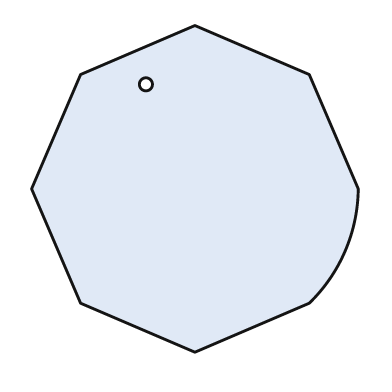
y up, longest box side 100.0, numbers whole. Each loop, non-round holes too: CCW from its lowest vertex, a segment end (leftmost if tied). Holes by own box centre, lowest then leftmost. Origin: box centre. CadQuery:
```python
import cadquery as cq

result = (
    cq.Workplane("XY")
    .moveTo(0.0, -50.0)
    .lineTo(35.0, -35.0)
    .threePointArc((46.0, -19.0), (50.0, 0.0))
    .lineTo(35.0, 35.0)
    .lineTo(0.0, 50.0)
    .lineTo(-35.0, 35.0)
    .lineTo(-50.0, 0.0)
    .lineTo(-35.0, -35.0)
    .close()
    .moveTo(-15.0, 32.0)
    .circle(2.0)
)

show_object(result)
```